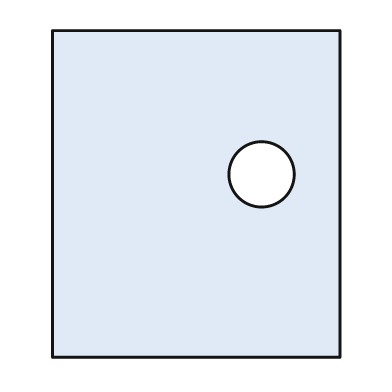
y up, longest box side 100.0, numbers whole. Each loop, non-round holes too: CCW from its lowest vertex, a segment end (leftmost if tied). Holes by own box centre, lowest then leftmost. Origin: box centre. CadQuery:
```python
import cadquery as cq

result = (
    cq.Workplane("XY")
    .moveTo(-44.0, -50.0)
    .lineTo(44.0, -50.0)
    .lineTo(44.0, 50.0)
    .lineTo(-44.0, 50.0)
    .close()
    .moveTo(20.0, 6.0)
    .circle(10.0)
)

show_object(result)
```